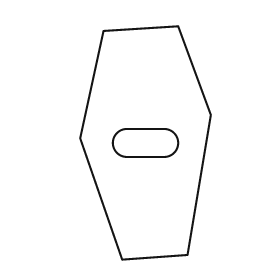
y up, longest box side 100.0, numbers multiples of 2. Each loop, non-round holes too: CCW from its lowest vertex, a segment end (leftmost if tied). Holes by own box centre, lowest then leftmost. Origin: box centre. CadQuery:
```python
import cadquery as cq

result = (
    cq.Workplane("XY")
    .moveTo(-10.0, -50.0)
    .lineTo(18.0, -48.0)
    .lineTo(28.0, 12.0)
    .lineTo(14.0, 50.0)
    .lineTo(-18.0, 48.0)
    .lineTo(-28.0, 2.0)
    .close()
    .moveTo(-8.0, -6.0)
    .lineTo(8.0, -6.0)
    .threePointArc((14.0, 0.0), (8.0, 6.0))
    .lineTo(-8.0, 6.0)
    .threePointArc((-14.0, 0.0), (-8.0, -6.0))
    .close()
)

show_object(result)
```